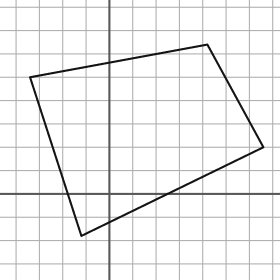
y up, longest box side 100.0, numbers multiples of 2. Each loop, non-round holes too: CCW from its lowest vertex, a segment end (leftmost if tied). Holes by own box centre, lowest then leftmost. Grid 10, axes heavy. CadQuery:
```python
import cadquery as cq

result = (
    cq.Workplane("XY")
    .moveTo(-12.0, -18.0)
    .lineTo(66.0, 20.0)
    .lineTo(42.0, 64.0)
    .lineTo(-34.0, 50.0)
    .close()
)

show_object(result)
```